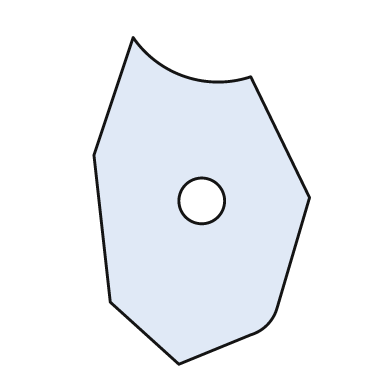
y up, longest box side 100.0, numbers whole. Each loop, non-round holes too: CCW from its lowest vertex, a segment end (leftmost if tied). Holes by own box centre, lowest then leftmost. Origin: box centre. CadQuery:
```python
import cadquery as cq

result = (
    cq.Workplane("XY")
    .moveTo(-7.0, -50.0)
    .lineTo(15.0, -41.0)
    .threePointArc((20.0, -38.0), (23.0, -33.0))
    .lineTo(33.0, 1.0)
    .lineTo(15.0, 38.0)
    .threePointArc((-5.0, 38.0), (-21.0, 50.0))
    .lineTo(-33.0, 14.0)
    .lineTo(-28.0, -31.0)
    .close()
    .moveTo(0.0, 0.0)
    .circle(7.0)
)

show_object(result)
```